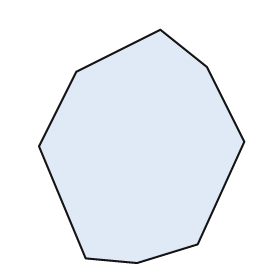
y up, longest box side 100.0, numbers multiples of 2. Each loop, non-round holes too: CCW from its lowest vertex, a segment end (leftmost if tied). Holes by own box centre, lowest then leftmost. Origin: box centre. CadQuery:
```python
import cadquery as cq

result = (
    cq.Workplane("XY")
    .moveTo(-2.0, -50.0)
    .lineTo(24.0, -42.0)
    .lineTo(44.0, 2.0)
    .lineTo(28.0, 34.0)
    .lineTo(8.0, 50.0)
    .lineTo(-28.0, 32.0)
    .lineTo(-44.0, 0.0)
    .lineTo(-24.0, -48.0)
    .close()
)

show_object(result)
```